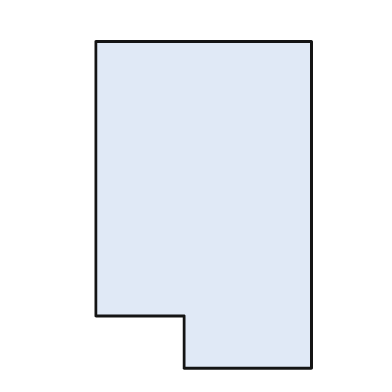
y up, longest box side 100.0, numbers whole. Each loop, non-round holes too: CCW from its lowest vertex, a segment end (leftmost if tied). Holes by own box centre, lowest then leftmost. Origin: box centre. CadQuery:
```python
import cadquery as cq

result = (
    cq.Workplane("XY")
    .moveTo(-6.0, -50.0)
    .lineTo(33.0, -50.0)
    .lineTo(33.0, 50.0)
    .lineTo(-33.0, 50.0)
    .lineTo(-33.0, -34.0)
    .lineTo(-6.0, -34.0)
    .close()
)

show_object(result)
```